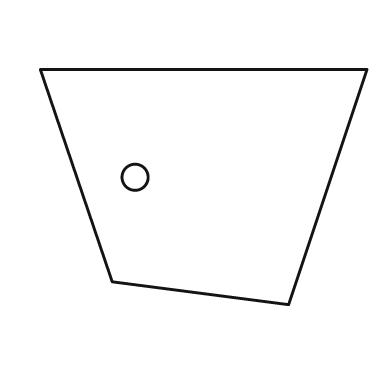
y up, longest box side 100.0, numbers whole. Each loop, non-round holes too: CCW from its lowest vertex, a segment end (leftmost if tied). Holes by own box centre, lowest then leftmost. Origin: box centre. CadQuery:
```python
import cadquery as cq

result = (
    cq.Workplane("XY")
    .moveTo(26.0, -36.0)
    .lineTo(50.0, 36.0)
    .lineTo(-50.0, 36.0)
    .lineTo(-28.0, -29.0)
    .close()
    .moveTo(-21.0, 3.0)
    .circle(4.0)
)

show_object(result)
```